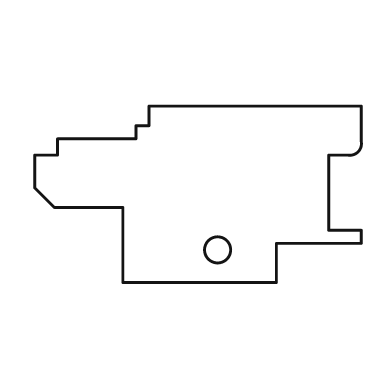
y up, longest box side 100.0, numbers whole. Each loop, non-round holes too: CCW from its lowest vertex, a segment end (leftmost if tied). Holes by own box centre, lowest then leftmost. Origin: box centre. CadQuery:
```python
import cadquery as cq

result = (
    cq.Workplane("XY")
    .moveTo(-23.0, -27.0)
    .lineTo(24.0, -27.0)
    .lineTo(24.0, -15.0)
    .lineTo(50.0, -15.0)
    .lineTo(50.0, -11.0)
    .lineTo(40.0, -11.0)
    .lineTo(40.0, 12.0)
    .lineTo(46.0, 12.0)
    .threePointArc((49.0, 13.0), (50.0, 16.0))
    .lineTo(50.0, 27.0)
    .lineTo(-15.0, 27.0)
    .lineTo(-15.0, 21.0)
    .lineTo(-19.0, 21.0)
    .lineTo(-19.0, 17.0)
    .lineTo(-43.0, 17.0)
    .lineTo(-43.0, 12.0)
    .lineTo(-50.0, 12.0)
    .lineTo(-50.0, 2.0)
    .lineTo(-44.0, -4.0)
    .lineTo(-23.0, -4.0)
    .close()
    .moveTo(6.0, -17.0)
    .circle(4.0)
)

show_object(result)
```